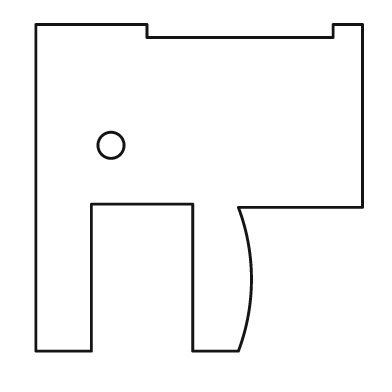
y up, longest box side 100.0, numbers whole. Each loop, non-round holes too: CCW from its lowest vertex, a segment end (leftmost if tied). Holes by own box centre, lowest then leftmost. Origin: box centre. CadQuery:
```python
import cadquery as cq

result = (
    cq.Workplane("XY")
    .moveTo(-50.0, -50.0)
    .lineTo(-33.0, -50.0)
    .lineTo(-33.0, -5.0)
    .lineTo(-2.0, -5.0)
    .lineTo(-2.0, -50.0)
    .lineTo(12.0, -50.0)
    .threePointArc((16.0, -28.0), (12.0, -6.0))
    .lineTo(50.0, -6.0)
    .lineTo(50.0, 50.0)
    .lineTo(41.0, 50.0)
    .lineTo(41.0, 46.0)
    .lineTo(-16.0, 46.0)
    .lineTo(-16.0, 50.0)
    .lineTo(-50.0, 50.0)
    .close()
    .moveTo(-27.0, 13.0)
    .circle(4.0)
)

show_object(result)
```